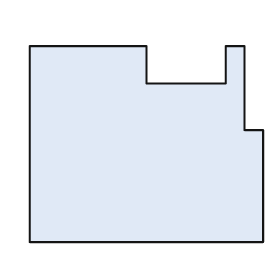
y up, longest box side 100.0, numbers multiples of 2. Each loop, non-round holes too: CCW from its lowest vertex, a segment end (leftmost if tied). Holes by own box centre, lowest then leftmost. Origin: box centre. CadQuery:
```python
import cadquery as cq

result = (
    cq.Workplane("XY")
    .moveTo(-50.0, -42.0)
    .lineTo(50.0, -42.0)
    .lineTo(50.0, 6.0)
    .lineTo(42.0, 6.0)
    .lineTo(42.0, 42.0)
    .lineTo(34.0, 42.0)
    .lineTo(34.0, 26.0)
    .lineTo(0.0, 26.0)
    .lineTo(0.0, 42.0)
    .lineTo(-50.0, 42.0)
    .close()
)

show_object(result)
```